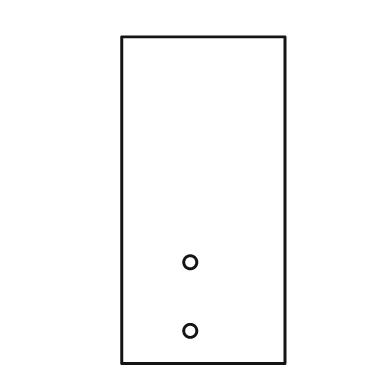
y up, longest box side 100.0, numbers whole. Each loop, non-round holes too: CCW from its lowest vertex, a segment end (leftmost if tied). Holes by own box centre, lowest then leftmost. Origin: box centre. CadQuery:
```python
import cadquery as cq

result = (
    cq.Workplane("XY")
    .moveTo(-25.0, -50.0)
    .lineTo(25.0, -50.0)
    .lineTo(25.0, 50.0)
    .lineTo(-25.0, 50.0)
    .close()
    .moveTo(-4.0, -40.0)
    .circle(2.0)
    .moveTo(-4.0, -19.0)
    .circle(2.0)
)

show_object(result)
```